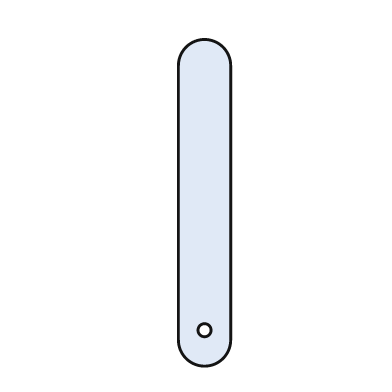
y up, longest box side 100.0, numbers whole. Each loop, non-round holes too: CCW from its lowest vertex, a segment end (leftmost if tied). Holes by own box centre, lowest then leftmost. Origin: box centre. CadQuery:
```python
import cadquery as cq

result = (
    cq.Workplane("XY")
    .moveTo(-8.0, -42.0)
    .threePointArc((0.0, -50.0), (8.0, -42.0))
    .lineTo(8.0, 42.0)
    .threePointArc((0.0, 50.0), (-8.0, 42.0))
    .close()
    .moveTo(0.0, -39.0)
    .circle(2.0)
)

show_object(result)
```